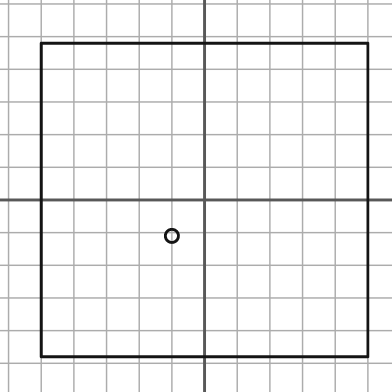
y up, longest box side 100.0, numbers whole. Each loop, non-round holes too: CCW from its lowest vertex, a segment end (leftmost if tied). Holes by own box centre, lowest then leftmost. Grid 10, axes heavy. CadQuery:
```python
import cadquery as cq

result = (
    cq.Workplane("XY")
    .moveTo(-50.0, -48.0)
    .lineTo(50.0, -48.0)
    .lineTo(50.0, 48.0)
    .lineTo(-50.0, 48.0)
    .close()
    .moveTo(-10.0, -11.0)
    .circle(2.0)
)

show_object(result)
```